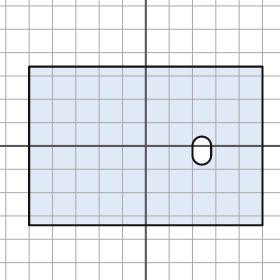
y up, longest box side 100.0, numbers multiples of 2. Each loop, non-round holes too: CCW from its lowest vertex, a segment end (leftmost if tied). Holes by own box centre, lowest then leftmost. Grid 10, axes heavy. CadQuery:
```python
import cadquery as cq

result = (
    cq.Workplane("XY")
    .moveTo(-50.0, -34.0)
    .lineTo(50.0, -34.0)
    .lineTo(50.0, 34.0)
    .lineTo(-50.0, 34.0)
    .close()
    .moveTo(20.0, -4.0)
    .threePointArc((24.0, -8.0), (28.0, -4.0))
    .lineTo(28.0, 0.0)
    .threePointArc((24.0, 4.0), (20.0, 0.0))
    .close()
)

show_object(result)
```